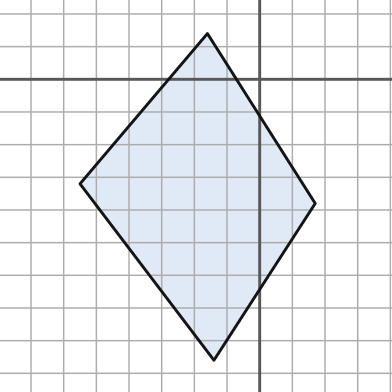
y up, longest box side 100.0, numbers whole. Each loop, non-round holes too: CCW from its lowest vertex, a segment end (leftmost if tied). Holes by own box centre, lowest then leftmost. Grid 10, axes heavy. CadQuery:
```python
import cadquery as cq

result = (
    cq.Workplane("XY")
    .moveTo(-14.0, -86.0)
    .lineTo(17.0, -38.0)
    .lineTo(-16.0, 14.0)
    .lineTo(-55.0, -32.0)
    .close()
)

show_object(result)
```